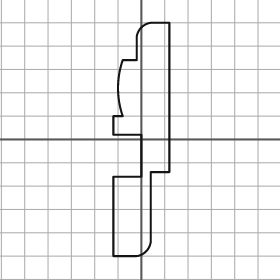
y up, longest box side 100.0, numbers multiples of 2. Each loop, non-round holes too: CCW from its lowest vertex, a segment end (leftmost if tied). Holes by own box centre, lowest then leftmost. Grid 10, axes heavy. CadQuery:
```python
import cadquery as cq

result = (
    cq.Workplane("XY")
    .moveTo(-12.0, -50.0)
    .lineTo(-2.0, -50.0)
    .threePointArc((2.0, -48.0), (4.0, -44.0))
    .lineTo(4.0, -14.0)
    .lineTo(12.0, -14.0)
    .lineTo(12.0, 50.0)
    .lineTo(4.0, 50.0)
    .threePointArc((0.0, 48.0), (-2.0, 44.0))
    .lineTo(-2.0, 34.0)
    .lineTo(-8.0, 34.0)
    .threePointArc((-10.0, 22.0), (-8.0, 10.0))
    .lineTo(-12.0, 10.0)
    .lineTo(-12.0, 2.0)
    .lineTo(0.0, 2.0)
    .lineTo(0.0, -16.0)
    .lineTo(-12.0, -16.0)
    .close()
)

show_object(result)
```